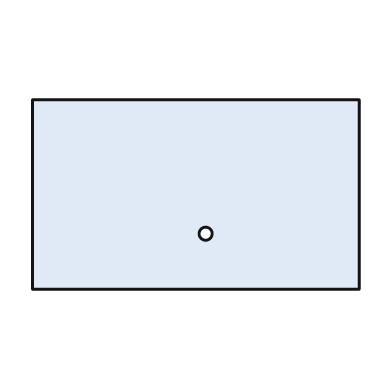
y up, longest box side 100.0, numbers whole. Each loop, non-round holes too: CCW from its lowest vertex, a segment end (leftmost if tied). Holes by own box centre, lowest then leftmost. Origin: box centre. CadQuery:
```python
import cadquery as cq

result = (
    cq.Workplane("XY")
    .moveTo(-50.0, -29.0)
    .lineTo(50.0, -29.0)
    .lineTo(50.0, 29.0)
    .lineTo(-50.0, 29.0)
    .close()
    .moveTo(3.0, -12.0)
    .circle(2.0)
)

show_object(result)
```